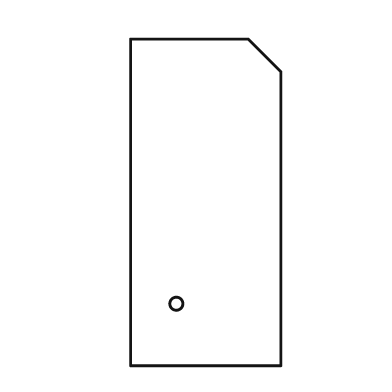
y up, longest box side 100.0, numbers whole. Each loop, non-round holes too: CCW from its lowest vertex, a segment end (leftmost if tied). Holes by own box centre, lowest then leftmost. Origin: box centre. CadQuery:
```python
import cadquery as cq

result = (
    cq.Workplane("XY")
    .moveTo(-23.0, -50.0)
    .lineTo(23.0, -50.0)
    .lineTo(23.0, 40.0)
    .lineTo(13.0, 50.0)
    .lineTo(-23.0, 50.0)
    .close()
    .moveTo(-9.0, -31.0)
    .circle(2.0)
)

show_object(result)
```